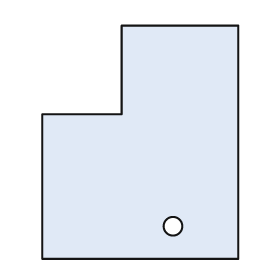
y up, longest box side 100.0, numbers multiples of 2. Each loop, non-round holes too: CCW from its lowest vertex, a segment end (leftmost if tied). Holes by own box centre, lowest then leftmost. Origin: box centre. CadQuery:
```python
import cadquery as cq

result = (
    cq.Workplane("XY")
    .moveTo(-42.0, -50.0)
    .lineTo(42.0, -50.0)
    .lineTo(42.0, 50.0)
    .lineTo(-8.0, 50.0)
    .lineTo(-8.0, 12.0)
    .lineTo(-42.0, 12.0)
    .close()
    .moveTo(14.0, -36.0)
    .circle(4.0)
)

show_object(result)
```